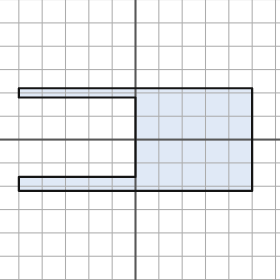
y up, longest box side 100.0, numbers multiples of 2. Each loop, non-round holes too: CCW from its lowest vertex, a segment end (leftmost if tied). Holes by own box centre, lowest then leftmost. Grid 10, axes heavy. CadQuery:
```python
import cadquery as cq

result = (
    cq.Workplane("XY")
    .moveTo(-50.0, -22.0)
    .lineTo(50.0, -22.0)
    .lineTo(50.0, 22.0)
    .lineTo(-50.0, 22.0)
    .lineTo(-50.0, 18.0)
    .lineTo(0.0, 18.0)
    .lineTo(0.0, -16.0)
    .lineTo(-50.0, -16.0)
    .close()
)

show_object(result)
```